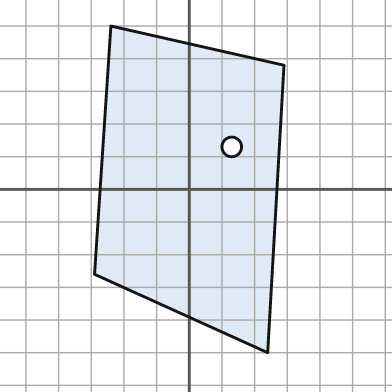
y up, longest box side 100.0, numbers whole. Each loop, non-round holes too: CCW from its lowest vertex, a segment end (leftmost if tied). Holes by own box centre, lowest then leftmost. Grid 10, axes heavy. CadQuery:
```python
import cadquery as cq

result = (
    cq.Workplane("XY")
    .moveTo(24.0, -50.0)
    .lineTo(29.0, 38.0)
    .lineTo(-24.0, 50.0)
    .lineTo(-29.0, -26.0)
    .close()
    .moveTo(13.0, 13.0)
    .circle(3.0)
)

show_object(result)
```